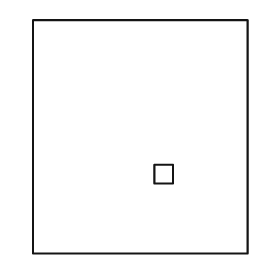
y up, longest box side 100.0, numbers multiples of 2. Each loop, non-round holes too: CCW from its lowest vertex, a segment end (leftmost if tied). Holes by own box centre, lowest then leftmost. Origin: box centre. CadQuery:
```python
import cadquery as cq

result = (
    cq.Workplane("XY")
    .moveTo(-46.0, -50.0)
    .lineTo(46.0, -50.0)
    .lineTo(46.0, 50.0)
    .lineTo(-46.0, 50.0)
    .close()
    .moveTo(6.0, -20.0)
    .lineTo(14.0, -20.0)
    .lineTo(14.0, -12.0)
    .lineTo(6.0, -12.0)
    .close()
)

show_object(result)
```